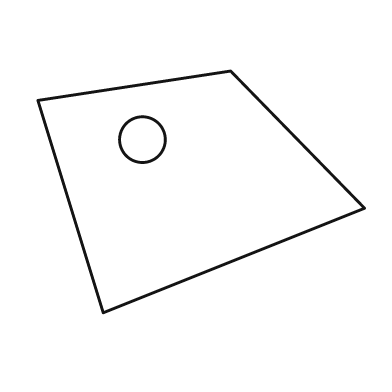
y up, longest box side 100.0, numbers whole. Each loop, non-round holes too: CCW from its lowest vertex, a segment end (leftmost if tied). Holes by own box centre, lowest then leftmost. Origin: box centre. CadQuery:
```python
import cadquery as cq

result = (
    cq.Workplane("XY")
    .moveTo(-30.0, -37.0)
    .lineTo(50.0, -5.0)
    .lineTo(9.0, 37.0)
    .lineTo(-50.0, 28.0)
    .close()
    .moveTo(-18.0, 16.0)
    .circle(7.0)
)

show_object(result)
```